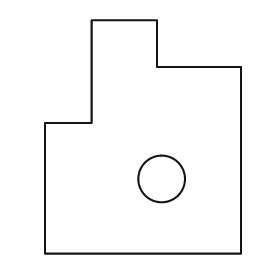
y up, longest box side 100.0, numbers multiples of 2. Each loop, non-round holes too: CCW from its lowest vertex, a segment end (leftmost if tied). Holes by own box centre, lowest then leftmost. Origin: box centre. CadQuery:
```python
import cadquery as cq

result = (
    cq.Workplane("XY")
    .moveTo(-42.0, -50.0)
    .lineTo(42.0, -50.0)
    .lineTo(42.0, 30.0)
    .lineTo(6.0, 30.0)
    .lineTo(6.0, 50.0)
    .lineTo(-22.0, 50.0)
    .lineTo(-22.0, 6.0)
    .lineTo(-42.0, 6.0)
    .close()
    .moveTo(8.0, -18.0)
    .circle(10.0)
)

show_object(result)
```